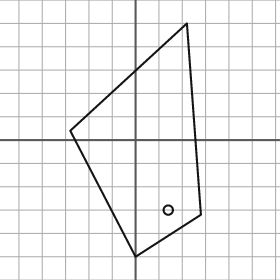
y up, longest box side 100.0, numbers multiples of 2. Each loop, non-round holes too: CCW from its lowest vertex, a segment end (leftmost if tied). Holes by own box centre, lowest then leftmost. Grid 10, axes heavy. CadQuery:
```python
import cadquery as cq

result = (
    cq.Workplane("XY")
    .moveTo(0.0, -50.0)
    .lineTo(28.0, -32.0)
    .lineTo(22.0, 50.0)
    .lineTo(-28.0, 4.0)
    .close()
    .moveTo(14.0, -30.0)
    .circle(2.0)
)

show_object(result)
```